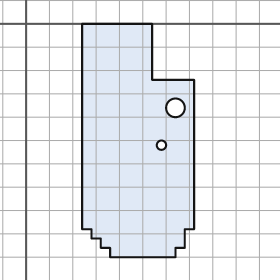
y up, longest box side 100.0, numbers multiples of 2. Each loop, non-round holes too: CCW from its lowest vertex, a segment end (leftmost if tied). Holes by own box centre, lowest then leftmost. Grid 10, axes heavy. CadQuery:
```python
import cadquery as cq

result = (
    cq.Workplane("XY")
    .moveTo(36.0, -100.0)
    .lineTo(64.0, -100.0)
    .lineTo(64.0, -96.0)
    .lineTo(68.0, -96.0)
    .lineTo(68.0, -88.0)
    .lineTo(72.0, -88.0)
    .lineTo(72.0, -24.0)
    .lineTo(54.0, -24.0)
    .lineTo(54.0, 0.0)
    .lineTo(24.0, 0.0)
    .lineTo(24.0, -88.0)
    .lineTo(28.0, -88.0)
    .lineTo(28.0, -92.0)
    .lineTo(32.0, -92.0)
    .lineTo(32.0, -96.0)
    .lineTo(36.0, -96.0)
    .close()
    .moveTo(58.0, -52.0)
    .circle(2.0)
    .moveTo(64.0, -36.0)
    .circle(4.0)
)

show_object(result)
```